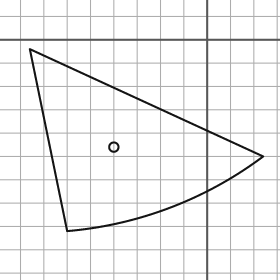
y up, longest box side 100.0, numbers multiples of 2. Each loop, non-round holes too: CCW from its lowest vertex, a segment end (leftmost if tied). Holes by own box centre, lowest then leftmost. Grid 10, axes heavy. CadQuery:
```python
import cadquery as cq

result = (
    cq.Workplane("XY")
    .moveTo(-60.0, -82.0)
    .threePointArc((-16.0, -72.0), (24.0, -50.0))
    .lineTo(-76.0, -4.0)
    .close()
    .moveTo(-40.0, -46.0)
    .circle(2.0)
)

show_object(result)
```